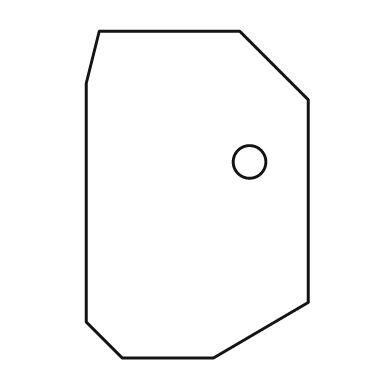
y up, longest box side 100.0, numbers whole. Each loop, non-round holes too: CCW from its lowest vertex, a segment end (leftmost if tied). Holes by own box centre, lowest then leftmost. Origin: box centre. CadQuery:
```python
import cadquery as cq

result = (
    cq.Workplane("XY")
    .moveTo(-23.0, -50.0)
    .lineTo(5.0, -50.0)
    .lineTo(34.0, -33.0)
    .lineTo(34.0, 29.0)
    .lineTo(13.0, 50.0)
    .lineTo(-30.0, 50.0)
    .lineTo(-34.0, 34.0)
    .lineTo(-34.0, -39.0)
    .close()
    .moveTo(16.0, 10.0)
    .circle(5.0)
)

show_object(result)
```